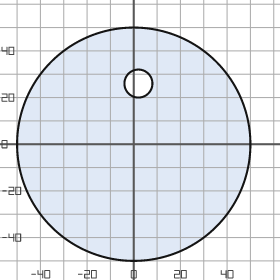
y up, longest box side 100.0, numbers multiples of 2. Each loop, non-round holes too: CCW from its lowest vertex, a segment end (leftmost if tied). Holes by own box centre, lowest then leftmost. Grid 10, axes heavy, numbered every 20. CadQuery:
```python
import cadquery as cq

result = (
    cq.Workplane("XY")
    .moveTo(0.0, 0.0)
    .circle(50.0)
    .moveTo(2.0, 26.0)
    .circle(6.0)
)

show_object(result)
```